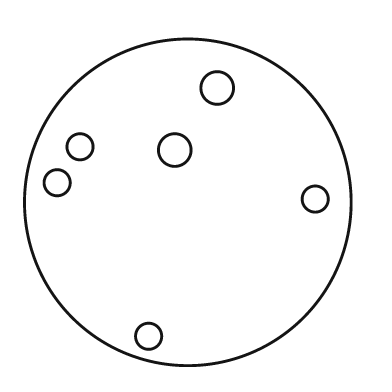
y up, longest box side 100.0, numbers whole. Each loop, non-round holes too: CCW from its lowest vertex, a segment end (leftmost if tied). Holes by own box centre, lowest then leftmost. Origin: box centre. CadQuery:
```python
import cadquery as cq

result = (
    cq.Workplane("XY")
    .moveTo(0.0, 0.0)
    .circle(50.0)
    .moveTo(-12.0, -41.0)
    .circle(4.0)
    .moveTo(39.0, 1.0)
    .circle(4.0)
    .moveTo(-40.0, 6.0)
    .circle(4.0)
    .moveTo(-4.0, 16.0)
    .circle(5.0)
    .moveTo(-33.0, 17.0)
    .circle(4.0)
    .moveTo(9.0, 35.0)
    .circle(5.0)
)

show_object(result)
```